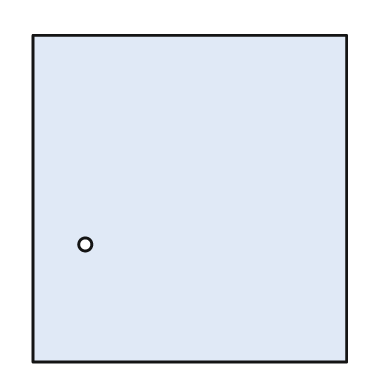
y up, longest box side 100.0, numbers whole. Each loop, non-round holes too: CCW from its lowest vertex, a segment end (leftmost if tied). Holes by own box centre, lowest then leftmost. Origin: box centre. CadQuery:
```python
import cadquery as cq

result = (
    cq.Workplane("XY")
    .moveTo(-48.0, -50.0)
    .lineTo(48.0, -50.0)
    .lineTo(48.0, 50.0)
    .lineTo(-48.0, 50.0)
    .close()
    .moveTo(-32.0, -14.0)
    .circle(2.0)
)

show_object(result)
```